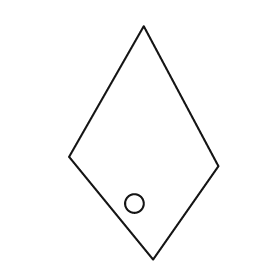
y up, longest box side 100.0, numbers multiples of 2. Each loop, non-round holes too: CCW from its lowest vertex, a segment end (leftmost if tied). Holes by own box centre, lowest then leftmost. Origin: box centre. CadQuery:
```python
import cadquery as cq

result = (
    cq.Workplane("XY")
    .moveTo(4.0, -50.0)
    .lineTo(32.0, -10.0)
    .lineTo(0.0, 50.0)
    .lineTo(-32.0, -6.0)
    .close()
    .moveTo(-4.0, -26.0)
    .circle(4.0)
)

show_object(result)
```